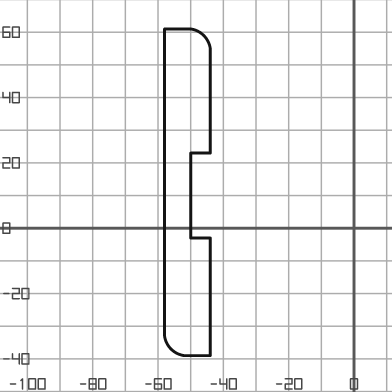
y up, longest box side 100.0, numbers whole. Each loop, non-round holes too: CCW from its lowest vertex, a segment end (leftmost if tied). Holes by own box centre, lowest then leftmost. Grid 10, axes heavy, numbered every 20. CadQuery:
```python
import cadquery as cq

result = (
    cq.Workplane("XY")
    .moveTo(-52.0, -39.0)
    .lineTo(-44.0, -39.0)
    .lineTo(-44.0, -3.0)
    .lineTo(-50.0, -3.0)
    .lineTo(-50.0, 23.0)
    .lineTo(-44.0, 23.0)
    .lineTo(-44.0, 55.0)
    .threePointArc((-46.0, 59.0), (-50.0, 61.0))
    .lineTo(-58.0, 61.0)
    .lineTo(-58.0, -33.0)
    .threePointArc((-56.0, -37.0), (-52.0, -39.0))
    .close()
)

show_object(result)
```